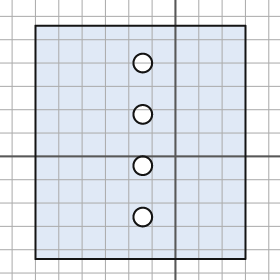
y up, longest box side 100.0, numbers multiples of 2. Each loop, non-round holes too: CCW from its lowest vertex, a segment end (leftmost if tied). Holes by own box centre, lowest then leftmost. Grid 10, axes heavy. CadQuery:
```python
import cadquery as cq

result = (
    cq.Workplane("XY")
    .moveTo(-60.0, -44.0)
    .lineTo(30.0, -44.0)
    .lineTo(30.0, 56.0)
    .lineTo(-60.0, 56.0)
    .close()
    .moveTo(-14.0, -26.0)
    .circle(4.0)
    .moveTo(-14.0, -4.0)
    .circle(4.0)
    .moveTo(-14.0, 18.0)
    .circle(4.0)
    .moveTo(-14.0, 40.0)
    .circle(4.0)
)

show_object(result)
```